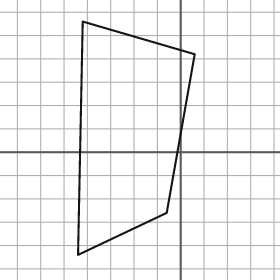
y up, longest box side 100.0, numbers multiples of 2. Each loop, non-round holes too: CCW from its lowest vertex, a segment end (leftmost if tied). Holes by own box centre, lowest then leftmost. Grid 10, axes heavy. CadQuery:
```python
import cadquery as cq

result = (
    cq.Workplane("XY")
    .moveTo(-44.0, -44.0)
    .lineTo(-6.0, -26.0)
    .lineTo(6.0, 42.0)
    .lineTo(-42.0, 56.0)
    .close()
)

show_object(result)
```